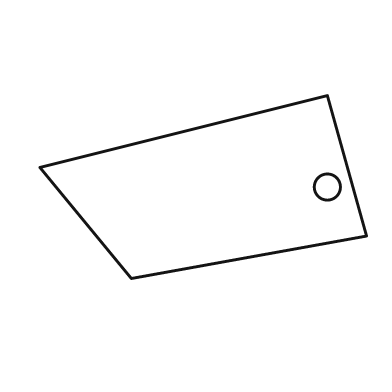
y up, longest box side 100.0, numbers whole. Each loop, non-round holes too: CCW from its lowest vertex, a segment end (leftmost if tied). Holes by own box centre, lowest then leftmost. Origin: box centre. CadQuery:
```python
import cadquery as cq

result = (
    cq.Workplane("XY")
    .moveTo(-22.0, -28.0)
    .lineTo(50.0, -15.0)
    .lineTo(38.0, 28.0)
    .lineTo(-50.0, 6.0)
    .close()
    .moveTo(38.0, 0.0)
    .circle(4.0)
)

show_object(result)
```